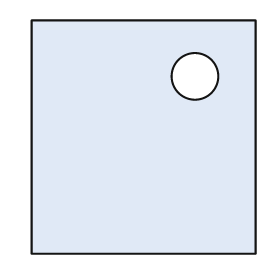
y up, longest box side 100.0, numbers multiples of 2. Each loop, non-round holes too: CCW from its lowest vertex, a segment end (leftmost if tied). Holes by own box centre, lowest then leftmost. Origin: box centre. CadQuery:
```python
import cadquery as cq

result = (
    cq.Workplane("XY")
    .moveTo(-48.0, -50.0)
    .lineTo(48.0, -50.0)
    .lineTo(48.0, 50.0)
    .lineTo(-48.0, 50.0)
    .close()
    .moveTo(22.0, 26.0)
    .circle(10.0)
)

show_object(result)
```